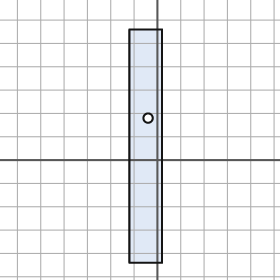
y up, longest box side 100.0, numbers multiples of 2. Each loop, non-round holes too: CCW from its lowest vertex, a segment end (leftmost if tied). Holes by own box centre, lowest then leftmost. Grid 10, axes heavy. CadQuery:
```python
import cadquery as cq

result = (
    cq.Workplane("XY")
    .moveTo(-12.0, -44.0)
    .lineTo(2.0, -44.0)
    .lineTo(2.0, 56.0)
    .lineTo(-12.0, 56.0)
    .close()
    .moveTo(-4.0, 18.0)
    .circle(2.0)
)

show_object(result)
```